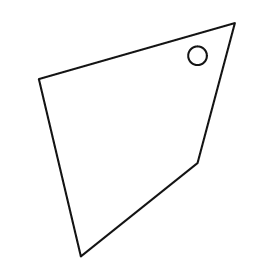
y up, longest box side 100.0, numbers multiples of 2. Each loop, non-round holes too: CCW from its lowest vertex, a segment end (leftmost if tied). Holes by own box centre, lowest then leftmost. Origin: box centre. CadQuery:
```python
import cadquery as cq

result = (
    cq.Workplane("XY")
    .moveTo(-24.0, -50.0)
    .lineTo(26.0, -10.0)
    .lineTo(42.0, 50.0)
    .lineTo(-42.0, 26.0)
    .close()
    .moveTo(26.0, 36.0)
    .circle(4.0)
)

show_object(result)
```